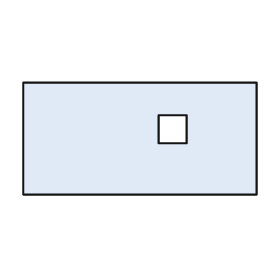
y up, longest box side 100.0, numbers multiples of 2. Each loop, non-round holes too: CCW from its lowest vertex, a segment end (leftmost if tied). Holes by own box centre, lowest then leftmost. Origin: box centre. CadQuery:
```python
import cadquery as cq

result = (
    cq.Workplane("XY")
    .moveTo(-50.0, -24.0)
    .lineTo(50.0, -24.0)
    .lineTo(50.0, 24.0)
    .lineTo(-50.0, 24.0)
    .close()
    .moveTo(8.0, -2.0)
    .lineTo(20.0, -2.0)
    .lineTo(20.0, 10.0)
    .lineTo(8.0, 10.0)
    .close()
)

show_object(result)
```